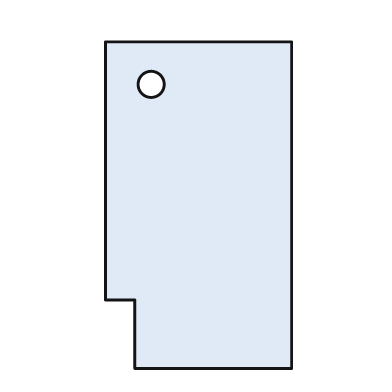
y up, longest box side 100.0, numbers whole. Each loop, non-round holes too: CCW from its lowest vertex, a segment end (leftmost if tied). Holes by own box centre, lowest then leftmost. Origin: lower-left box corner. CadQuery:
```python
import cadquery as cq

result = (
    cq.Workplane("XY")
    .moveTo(9.0, 0.0)
    .lineTo(57.0, 0.0)
    .lineTo(57.0, 100.0)
    .lineTo(0.0, 100.0)
    .lineTo(0.0, 21.0)
    .lineTo(9.0, 21.0)
    .close()
    .moveTo(14.0, 87.0)
    .circle(4.0)
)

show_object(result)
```